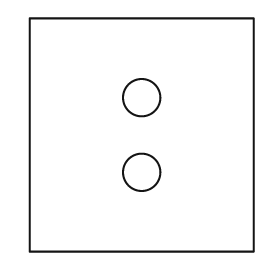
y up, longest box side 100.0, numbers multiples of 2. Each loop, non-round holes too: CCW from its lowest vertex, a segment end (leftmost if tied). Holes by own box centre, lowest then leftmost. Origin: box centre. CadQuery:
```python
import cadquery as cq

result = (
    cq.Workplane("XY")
    .moveTo(-48.0, -50.0)
    .lineTo(48.0, -50.0)
    .lineTo(48.0, 50.0)
    .lineTo(-48.0, 50.0)
    .close()
    .moveTo(0.0, -16.0)
    .circle(8.0)
    .moveTo(0.0, 16.0)
    .circle(8.0)
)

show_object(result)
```